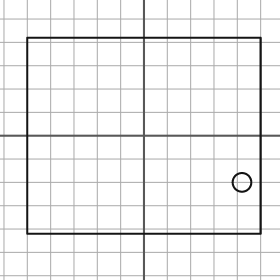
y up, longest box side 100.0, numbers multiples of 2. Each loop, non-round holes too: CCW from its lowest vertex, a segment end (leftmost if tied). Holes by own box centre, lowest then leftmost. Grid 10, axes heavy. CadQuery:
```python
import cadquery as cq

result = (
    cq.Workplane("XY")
    .moveTo(-50.0, -42.0)
    .lineTo(50.0, -42.0)
    .lineTo(50.0, 42.0)
    .lineTo(-50.0, 42.0)
    .close()
    .moveTo(42.0, -20.0)
    .circle(4.0)
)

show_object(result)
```